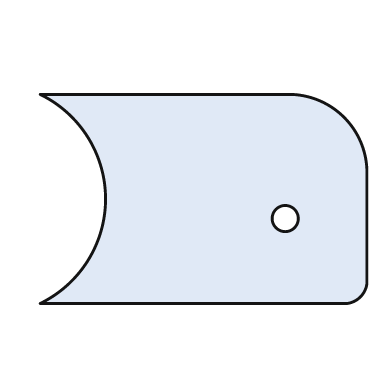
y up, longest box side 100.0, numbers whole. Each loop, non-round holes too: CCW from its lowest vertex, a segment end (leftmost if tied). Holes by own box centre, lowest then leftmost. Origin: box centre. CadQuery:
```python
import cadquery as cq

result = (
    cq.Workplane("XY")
    .moveTo(-50.0, -32.0)
    .lineTo(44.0, -32.0)
    .threePointArc((48.0, -30.0), (50.0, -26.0))
    .lineTo(50.0, 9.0)
    .threePointArc((43.0, 25.0), (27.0, 32.0))
    .lineTo(-50.0, 32.0)
    .threePointArc((-30.0, 0.0), (-50.0, -32.0))
    .close()
    .moveTo(25.0, -6.0)
    .circle(4.0)
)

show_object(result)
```